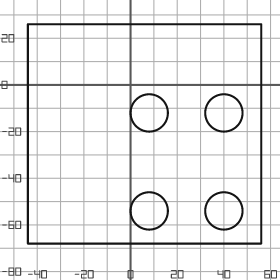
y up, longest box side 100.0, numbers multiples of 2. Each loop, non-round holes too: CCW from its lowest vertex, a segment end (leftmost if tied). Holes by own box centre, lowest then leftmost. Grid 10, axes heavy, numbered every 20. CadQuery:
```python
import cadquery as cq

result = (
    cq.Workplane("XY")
    .moveTo(-44.0, -68.0)
    .lineTo(56.0, -68.0)
    .lineTo(56.0, 26.0)
    .lineTo(-44.0, 26.0)
    .close()
    .moveTo(8.0, -54.0)
    .circle(8.0)
    .moveTo(40.0, -54.0)
    .circle(8.0)
    .moveTo(8.0, -12.0)
    .circle(8.0)
    .moveTo(40.0, -12.0)
    .circle(8.0)
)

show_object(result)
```